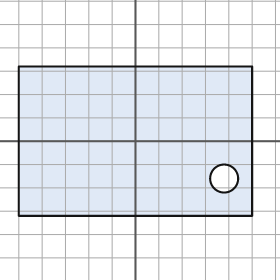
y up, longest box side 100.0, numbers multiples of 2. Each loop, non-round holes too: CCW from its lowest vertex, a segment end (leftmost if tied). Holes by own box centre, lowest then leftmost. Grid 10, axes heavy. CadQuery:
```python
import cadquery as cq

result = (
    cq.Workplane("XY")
    .moveTo(-50.0, -32.0)
    .lineTo(50.0, -32.0)
    .lineTo(50.0, 32.0)
    .lineTo(-50.0, 32.0)
    .close()
    .moveTo(38.0, -16.0)
    .circle(6.0)
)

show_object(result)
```